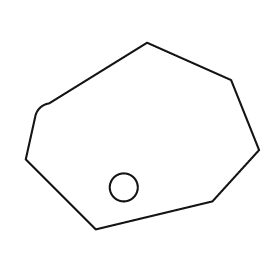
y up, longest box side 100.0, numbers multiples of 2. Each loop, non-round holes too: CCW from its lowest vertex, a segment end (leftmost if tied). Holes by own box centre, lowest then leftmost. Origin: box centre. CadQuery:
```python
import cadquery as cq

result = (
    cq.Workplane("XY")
    .moveTo(-20.0, -40.0)
    .lineTo(30.0, -28.0)
    .lineTo(50.0, -6.0)
    .lineTo(38.0, 24.0)
    .lineTo(2.0, 40.0)
    .lineTo(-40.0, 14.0)
    .threePointArc((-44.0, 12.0), (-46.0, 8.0))
    .lineTo(-50.0, -10.0)
    .close()
    .moveTo(-8.0, -22.0)
    .circle(6.0)
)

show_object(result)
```